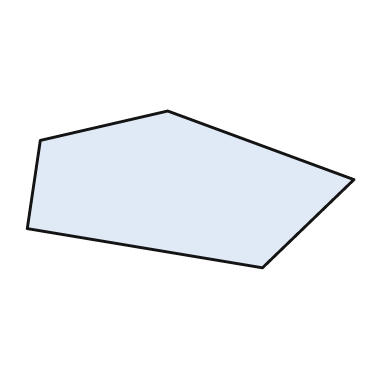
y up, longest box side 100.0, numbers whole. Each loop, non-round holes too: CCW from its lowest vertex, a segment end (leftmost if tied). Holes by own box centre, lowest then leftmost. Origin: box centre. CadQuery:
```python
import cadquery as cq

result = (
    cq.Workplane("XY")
    .moveTo(22.0, -24.0)
    .lineTo(50.0, 3.0)
    .lineTo(-7.0, 24.0)
    .lineTo(-46.0, 15.0)
    .lineTo(-50.0, -12.0)
    .close()
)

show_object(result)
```